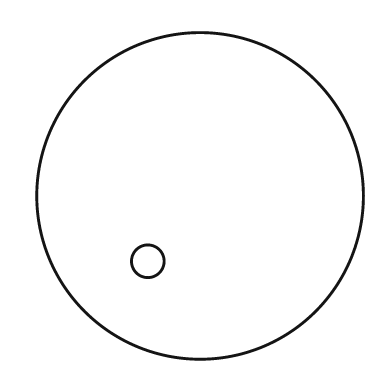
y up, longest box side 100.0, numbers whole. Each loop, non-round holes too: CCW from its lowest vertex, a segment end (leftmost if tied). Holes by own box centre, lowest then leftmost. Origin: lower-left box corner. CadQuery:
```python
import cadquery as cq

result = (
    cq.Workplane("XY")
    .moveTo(50.0, 50.0)
    .circle(50.0)
    .moveTo(34.0, 30.0)
    .circle(5.0)
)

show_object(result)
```